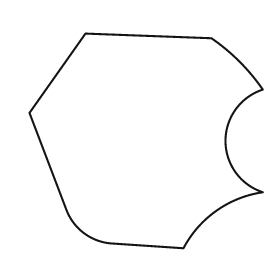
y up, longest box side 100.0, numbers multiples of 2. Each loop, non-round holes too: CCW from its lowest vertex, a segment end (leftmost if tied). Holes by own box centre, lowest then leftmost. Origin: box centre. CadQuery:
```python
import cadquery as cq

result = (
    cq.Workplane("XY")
    .moveTo(16.0, -46.0)
    .threePointArc((30.0, -30.0), (50.0, -22.0))
    .threePointArc((34.0, 0.0), (50.0, 22.0))
    .threePointArc((40.0, 34.0), (28.0, 44.0))
    .lineTo(-26.0, 46.0)
    .lineTo(-50.0, 12.0)
    .lineTo(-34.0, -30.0)
    .threePointArc((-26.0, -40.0), (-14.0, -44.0))
    .close()
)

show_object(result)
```